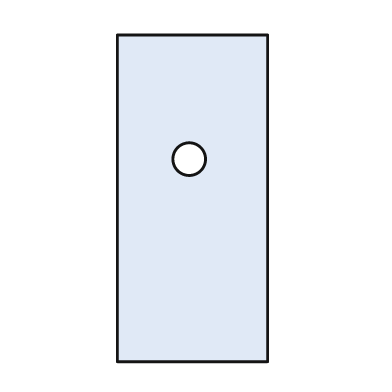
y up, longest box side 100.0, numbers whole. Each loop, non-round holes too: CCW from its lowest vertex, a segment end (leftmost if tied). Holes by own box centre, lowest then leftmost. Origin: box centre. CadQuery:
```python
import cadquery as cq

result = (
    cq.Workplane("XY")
    .moveTo(-23.0, -50.0)
    .lineTo(23.0, -50.0)
    .lineTo(23.0, 50.0)
    .lineTo(-23.0, 50.0)
    .close()
    .moveTo(-1.0, 12.0)
    .circle(5.0)
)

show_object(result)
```